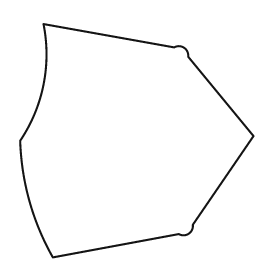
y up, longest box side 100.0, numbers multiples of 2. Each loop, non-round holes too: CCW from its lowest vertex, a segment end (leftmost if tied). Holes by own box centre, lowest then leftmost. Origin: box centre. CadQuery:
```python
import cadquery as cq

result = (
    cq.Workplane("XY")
    .moveTo(-36.0, -50.0)
    .lineTo(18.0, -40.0)
    .threePointArc((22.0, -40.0), (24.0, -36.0))
    .lineTo(50.0, 2.0)
    .lineTo(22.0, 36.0)
    .threePointArc((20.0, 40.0), (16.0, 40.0))
    .lineTo(-40.0, 50.0)
    .threePointArc((-40.0, 24.0), (-50.0, 0.0))
    .threePointArc((-46.0, -26.0), (-36.0, -50.0))
    .close()
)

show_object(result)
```